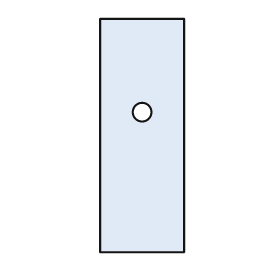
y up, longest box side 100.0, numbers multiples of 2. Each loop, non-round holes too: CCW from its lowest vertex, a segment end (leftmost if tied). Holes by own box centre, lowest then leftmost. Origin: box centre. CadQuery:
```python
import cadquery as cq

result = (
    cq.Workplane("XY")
    .moveTo(-18.0, -50.0)
    .lineTo(18.0, -50.0)
    .lineTo(18.0, 50.0)
    .lineTo(-18.0, 50.0)
    .close()
    .moveTo(0.0, 10.0)
    .circle(4.0)
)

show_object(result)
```